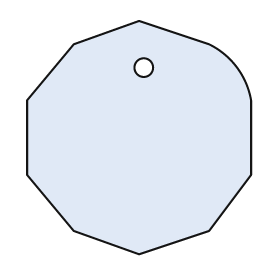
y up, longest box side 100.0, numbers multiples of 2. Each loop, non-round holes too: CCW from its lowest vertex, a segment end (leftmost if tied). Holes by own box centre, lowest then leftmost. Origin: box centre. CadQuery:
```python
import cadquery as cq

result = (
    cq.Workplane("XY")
    .moveTo(0.0, -50.0)
    .lineTo(30.0, -40.0)
    .lineTo(48.0, -16.0)
    .lineTo(48.0, 16.0)
    .threePointArc((42.0, 30.0), (30.0, 40.0))
    .lineTo(0.0, 50.0)
    .lineTo(-28.0, 40.0)
    .lineTo(-48.0, 16.0)
    .lineTo(-48.0, -16.0)
    .lineTo(-28.0, -40.0)
    .close()
    .moveTo(2.0, 30.0)
    .circle(4.0)
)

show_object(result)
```